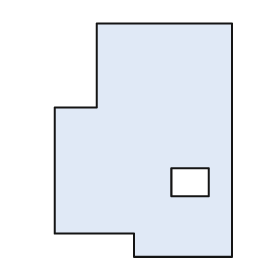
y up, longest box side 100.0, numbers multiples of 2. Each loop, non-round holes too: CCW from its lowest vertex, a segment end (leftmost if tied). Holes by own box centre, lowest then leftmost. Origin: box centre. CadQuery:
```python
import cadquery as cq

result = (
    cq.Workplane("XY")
    .moveTo(-4.0, -50.0)
    .lineTo(38.0, -50.0)
    .lineTo(38.0, 50.0)
    .lineTo(-20.0, 50.0)
    .lineTo(-20.0, 14.0)
    .lineTo(-38.0, 14.0)
    .lineTo(-38.0, -40.0)
    .lineTo(-4.0, -40.0)
    .close()
    .moveTo(12.0, -24.0)
    .lineTo(28.0, -24.0)
    .lineTo(28.0, -12.0)
    .lineTo(12.0, -12.0)
    .close()
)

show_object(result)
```